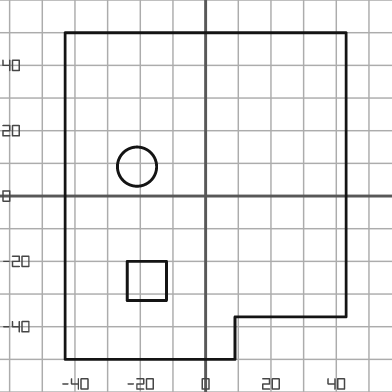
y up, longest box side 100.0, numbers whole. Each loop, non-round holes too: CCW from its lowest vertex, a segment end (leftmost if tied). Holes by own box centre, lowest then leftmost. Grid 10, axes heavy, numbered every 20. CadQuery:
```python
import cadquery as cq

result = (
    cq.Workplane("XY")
    .moveTo(-43.0, -50.0)
    .lineTo(9.0, -50.0)
    .lineTo(9.0, -37.0)
    .lineTo(43.0, -37.0)
    .lineTo(43.0, 50.0)
    .lineTo(-43.0, 50.0)
    .close()
    .moveTo(-24.0, -32.0)
    .lineTo(-12.0, -32.0)
    .lineTo(-12.0, -20.0)
    .lineTo(-24.0, -20.0)
    .close()
    .moveTo(-21.0, 9.0)
    .circle(6.0)
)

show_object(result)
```